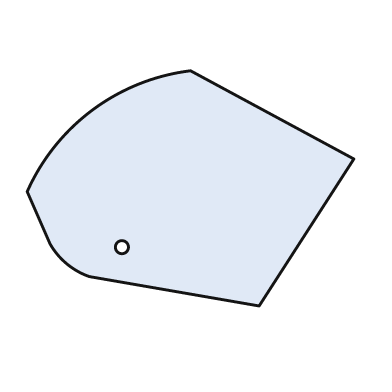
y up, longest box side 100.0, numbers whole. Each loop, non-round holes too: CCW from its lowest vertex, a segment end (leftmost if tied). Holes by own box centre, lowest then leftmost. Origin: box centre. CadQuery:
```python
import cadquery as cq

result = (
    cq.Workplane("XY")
    .moveTo(21.0, -36.0)
    .lineTo(50.0, 9.0)
    .lineTo(0.0, 36.0)
    .threePointArc((-30.0, 24.0), (-50.0, -1.0))
    .lineTo(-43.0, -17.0)
    .threePointArc((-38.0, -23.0), (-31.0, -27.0))
    .close()
    .moveTo(-21.0, -18.0)
    .circle(2.0)
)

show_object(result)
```